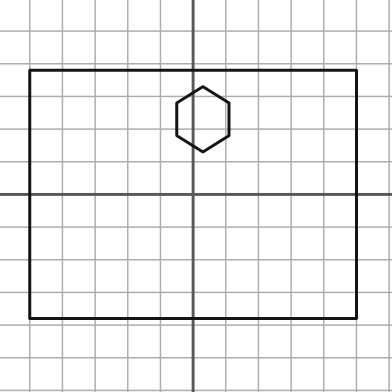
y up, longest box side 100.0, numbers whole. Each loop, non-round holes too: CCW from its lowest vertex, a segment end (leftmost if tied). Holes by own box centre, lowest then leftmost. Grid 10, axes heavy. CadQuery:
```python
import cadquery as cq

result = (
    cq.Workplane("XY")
    .moveTo(-50.0, -38.0)
    .lineTo(50.0, -38.0)
    .lineTo(50.0, 38.0)
    .lineTo(-50.0, 38.0)
    .close()
    .moveTo(3.0, 13.0)
    .lineTo(11.0, 18.0)
    .lineTo(11.0, 28.0)
    .lineTo(3.0, 33.0)
    .lineTo(-5.0, 28.0)
    .lineTo(-5.0, 18.0)
    .close()
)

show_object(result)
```